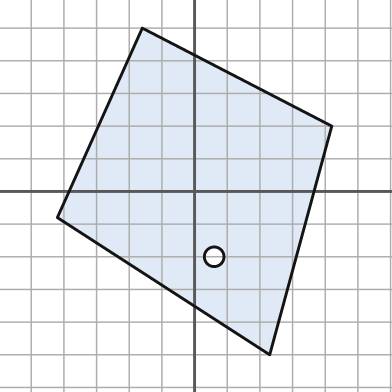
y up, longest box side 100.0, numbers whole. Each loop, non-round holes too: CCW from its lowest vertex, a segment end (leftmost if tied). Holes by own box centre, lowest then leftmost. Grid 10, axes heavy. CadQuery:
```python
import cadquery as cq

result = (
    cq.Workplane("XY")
    .moveTo(23.0, -50.0)
    .lineTo(42.0, 20.0)
    .lineTo(-16.0, 50.0)
    .lineTo(-42.0, -8.0)
    .close()
    .moveTo(6.0, -20.0)
    .circle(3.0)
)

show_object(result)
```